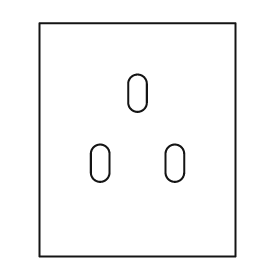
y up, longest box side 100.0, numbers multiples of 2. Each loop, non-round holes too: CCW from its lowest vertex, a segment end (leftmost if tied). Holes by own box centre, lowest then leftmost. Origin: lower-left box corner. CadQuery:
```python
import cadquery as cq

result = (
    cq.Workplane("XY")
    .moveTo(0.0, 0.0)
    .lineTo(84.0, 0.0)
    .lineTo(84.0, 100.0)
    .lineTo(0.0, 100.0)
    .close()
    .moveTo(22.0, 36.0)
    .threePointArc((26.0, 32.0), (30.0, 36.0))
    .lineTo(30.0, 44.0)
    .threePointArc((26.0, 48.0), (22.0, 44.0))
    .close()
    .moveTo(54.0, 36.0)
    .threePointArc((58.0, 32.0), (62.0, 36.0))
    .lineTo(62.0, 44.0)
    .threePointArc((58.0, 48.0), (54.0, 44.0))
    .close()
    .moveTo(38.0, 66.0)
    .threePointArc((42.0, 62.0), (46.0, 66.0))
    .lineTo(46.0, 74.0)
    .threePointArc((42.0, 78.0), (38.0, 74.0))
    .close()
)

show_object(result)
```